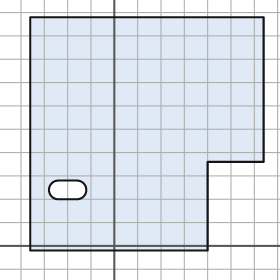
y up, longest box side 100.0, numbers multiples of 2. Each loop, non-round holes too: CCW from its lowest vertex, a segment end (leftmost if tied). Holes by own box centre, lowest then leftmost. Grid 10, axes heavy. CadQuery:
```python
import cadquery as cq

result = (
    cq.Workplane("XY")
    .moveTo(-36.0, -2.0)
    .lineTo(40.0, -2.0)
    .lineTo(40.0, 36.0)
    .lineTo(64.0, 36.0)
    .lineTo(64.0, 98.0)
    .lineTo(-36.0, 98.0)
    .close()
    .moveTo(-24.0, 20.0)
    .lineTo(-16.0, 20.0)
    .threePointArc((-12.0, 24.0), (-16.0, 28.0))
    .lineTo(-24.0, 28.0)
    .threePointArc((-28.0, 24.0), (-24.0, 20.0))
    .close()
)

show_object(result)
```